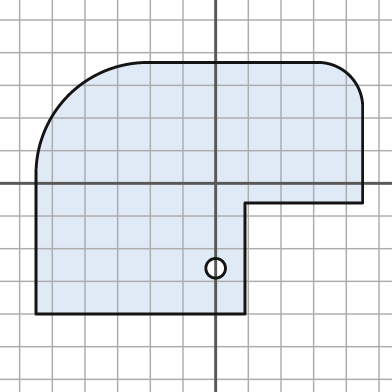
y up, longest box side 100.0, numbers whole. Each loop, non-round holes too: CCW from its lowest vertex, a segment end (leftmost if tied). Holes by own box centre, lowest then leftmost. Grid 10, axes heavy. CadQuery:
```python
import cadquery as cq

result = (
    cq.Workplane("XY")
    .moveTo(-55.0, -40.0)
    .lineTo(9.0, -40.0)
    .lineTo(9.0, -6.0)
    .lineTo(45.0, -6.0)
    .lineTo(45.0, 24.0)
    .threePointArc((41.0, 33.0), (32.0, 37.0))
    .lineTo(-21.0, 37.0)
    .threePointArc((-45.0, 27.0), (-55.0, 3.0))
    .close()
    .moveTo(0.0, -26.0)
    .circle(3.0)
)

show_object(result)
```